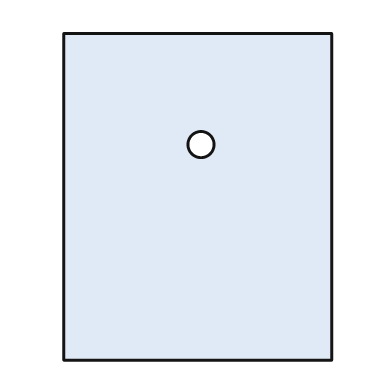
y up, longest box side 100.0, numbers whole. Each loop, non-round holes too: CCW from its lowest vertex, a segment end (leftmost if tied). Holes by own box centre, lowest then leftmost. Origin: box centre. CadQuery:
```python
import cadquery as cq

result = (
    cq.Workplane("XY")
    .moveTo(-41.0, -50.0)
    .lineTo(41.0, -50.0)
    .lineTo(41.0, 50.0)
    .lineTo(-41.0, 50.0)
    .close()
    .moveTo(1.0, 16.0)
    .circle(4.0)
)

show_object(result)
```